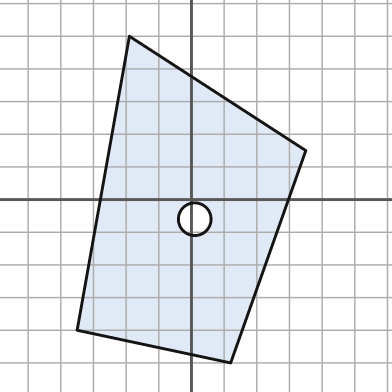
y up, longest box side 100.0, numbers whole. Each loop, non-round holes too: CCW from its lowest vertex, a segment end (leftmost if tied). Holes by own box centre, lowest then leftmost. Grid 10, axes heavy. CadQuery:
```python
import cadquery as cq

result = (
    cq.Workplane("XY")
    .moveTo(12.0, -50.0)
    .lineTo(35.0, 15.0)
    .lineTo(-19.0, 50.0)
    .lineTo(-35.0, -40.0)
    .close()
    .moveTo(1.0, -6.0)
    .circle(5.0)
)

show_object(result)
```